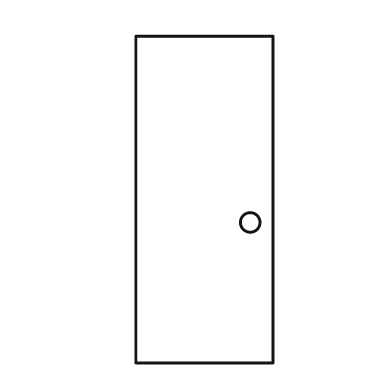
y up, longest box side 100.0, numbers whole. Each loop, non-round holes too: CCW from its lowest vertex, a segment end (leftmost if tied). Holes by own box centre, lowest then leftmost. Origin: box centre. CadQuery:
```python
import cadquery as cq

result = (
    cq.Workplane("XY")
    .moveTo(-21.0, -50.0)
    .lineTo(21.0, -50.0)
    .lineTo(21.0, 50.0)
    .lineTo(-21.0, 50.0)
    .close()
    .moveTo(14.0, -7.0)
    .circle(3.0)
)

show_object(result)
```